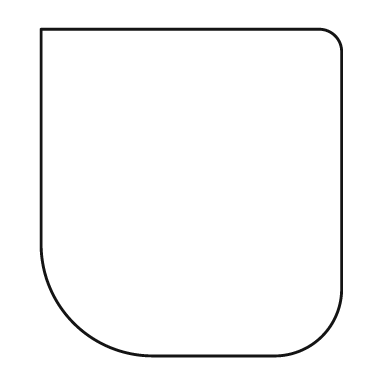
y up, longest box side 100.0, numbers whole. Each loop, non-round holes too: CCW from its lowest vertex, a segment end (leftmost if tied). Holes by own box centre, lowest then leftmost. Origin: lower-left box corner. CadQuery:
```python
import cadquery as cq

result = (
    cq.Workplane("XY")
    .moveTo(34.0, 0.0)
    .lineTo(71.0, 0.0)
    .threePointArc((86.0, 6.0), (92.0, 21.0))
    .lineTo(92.0, 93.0)
    .threePointArc((90.0, 98.0), (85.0, 100.0))
    .lineTo(0.0, 100.0)
    .lineTo(0.0, 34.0)
    .threePointArc((10.0, 10.0), (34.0, 0.0))
    .close()
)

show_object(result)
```